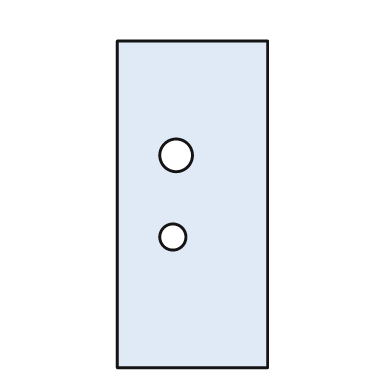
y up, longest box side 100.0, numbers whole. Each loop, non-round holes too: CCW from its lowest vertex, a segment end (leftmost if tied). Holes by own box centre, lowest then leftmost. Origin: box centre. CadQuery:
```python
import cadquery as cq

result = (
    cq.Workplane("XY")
    .moveTo(-23.0, -50.0)
    .lineTo(23.0, -50.0)
    .lineTo(23.0, 50.0)
    .lineTo(-23.0, 50.0)
    .close()
    .moveTo(-6.0, -10.0)
    .circle(4.0)
    .moveTo(-5.0, 15.0)
    .circle(5.0)
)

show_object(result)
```